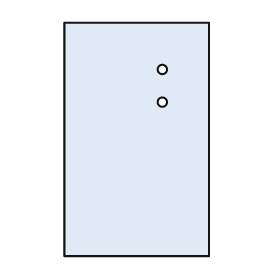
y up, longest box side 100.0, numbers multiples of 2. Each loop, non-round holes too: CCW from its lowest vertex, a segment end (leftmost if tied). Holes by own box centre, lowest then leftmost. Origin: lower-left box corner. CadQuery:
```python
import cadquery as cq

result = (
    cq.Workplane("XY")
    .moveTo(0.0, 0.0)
    .lineTo(62.0, 0.0)
    .lineTo(62.0, 100.0)
    .lineTo(0.0, 100.0)
    .close()
    .moveTo(42.0, 66.0)
    .circle(2.0)
    .moveTo(42.0, 80.0)
    .circle(2.0)
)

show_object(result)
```